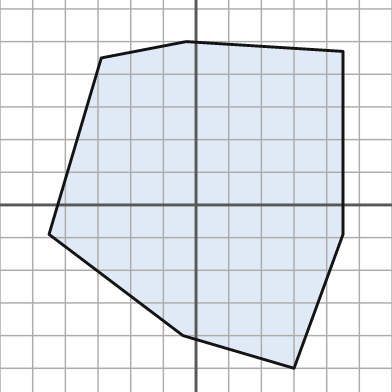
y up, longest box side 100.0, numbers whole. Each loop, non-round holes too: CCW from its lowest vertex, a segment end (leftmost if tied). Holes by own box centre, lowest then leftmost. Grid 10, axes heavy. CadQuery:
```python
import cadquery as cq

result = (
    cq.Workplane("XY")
    .moveTo(30.0, -50.0)
    .lineTo(45.0, -9.0)
    .lineTo(45.0, 47.0)
    .lineTo(-3.0, 50.0)
    .lineTo(-29.0, 45.0)
    .lineTo(-45.0, -9.0)
    .lineTo(-4.0, -40.0)
    .close()
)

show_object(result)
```